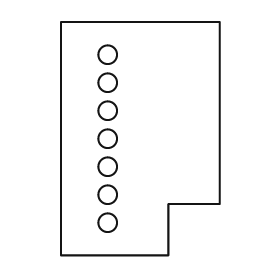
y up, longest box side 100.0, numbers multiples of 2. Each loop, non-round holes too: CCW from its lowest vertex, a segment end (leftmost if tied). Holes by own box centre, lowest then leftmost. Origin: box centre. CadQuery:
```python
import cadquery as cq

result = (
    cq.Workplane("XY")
    .moveTo(-34.0, -50.0)
    .lineTo(12.0, -50.0)
    .lineTo(12.0, -28.0)
    .lineTo(34.0, -28.0)
    .lineTo(34.0, 50.0)
    .lineTo(-34.0, 50.0)
    .close()
    .moveTo(-14.0, -36.0)
    .circle(4.0)
    .moveTo(-14.0, -24.0)
    .circle(4.0)
    .moveTo(-14.0, -12.0)
    .circle(4.0)
    .moveTo(-14.0, 0.0)
    .circle(4.0)
    .moveTo(-14.0, 12.0)
    .circle(4.0)
    .moveTo(-14.0, 24.0)
    .circle(4.0)
    .moveTo(-14.0, 36.0)
    .circle(4.0)
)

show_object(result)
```